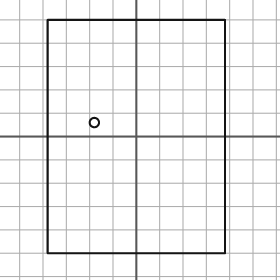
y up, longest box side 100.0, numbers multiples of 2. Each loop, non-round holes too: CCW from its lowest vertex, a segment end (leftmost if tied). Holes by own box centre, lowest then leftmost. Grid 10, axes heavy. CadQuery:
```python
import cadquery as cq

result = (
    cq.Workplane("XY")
    .moveTo(-38.0, -50.0)
    .lineTo(38.0, -50.0)
    .lineTo(38.0, 50.0)
    .lineTo(-38.0, 50.0)
    .close()
    .moveTo(-18.0, 6.0)
    .circle(2.0)
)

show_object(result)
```